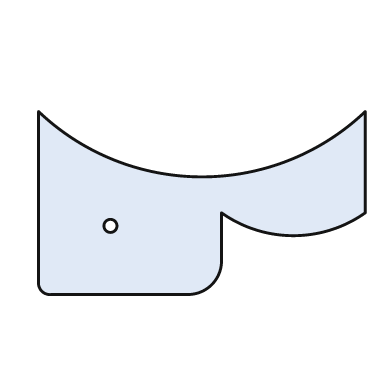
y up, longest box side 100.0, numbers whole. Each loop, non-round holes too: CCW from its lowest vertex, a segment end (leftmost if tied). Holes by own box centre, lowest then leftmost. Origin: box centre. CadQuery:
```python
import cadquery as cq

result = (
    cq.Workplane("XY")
    .moveTo(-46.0, -28.0)
    .lineTo(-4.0, -28.0)
    .threePointArc((3.0, -25.0), (6.0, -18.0))
    .lineTo(6.0, -3.0)
    .threePointArc((28.0, -10.0), (50.0, -3.0))
    .lineTo(50.0, 28.0)
    .threePointArc((0.0, 8.0), (-50.0, 28.0))
    .lineTo(-50.0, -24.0)
    .threePointArc((-49.0, -27.0), (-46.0, -28.0))
    .close()
    .moveTo(-28.0, -7.0)
    .circle(2.0)
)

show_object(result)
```